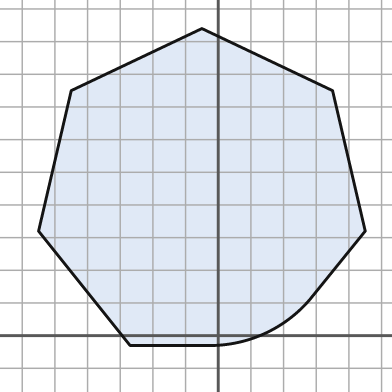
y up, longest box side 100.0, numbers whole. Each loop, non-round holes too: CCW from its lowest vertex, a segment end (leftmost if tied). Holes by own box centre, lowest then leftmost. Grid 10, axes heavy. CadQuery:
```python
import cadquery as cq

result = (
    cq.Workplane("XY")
    .moveTo(-27.0, -3.0)
    .lineTo(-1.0, -3.0)
    .threePointArc((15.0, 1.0), (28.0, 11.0))
    .lineTo(45.0, 32.0)
    .lineTo(35.0, 75.0)
    .lineTo(-5.0, 94.0)
    .lineTo(-45.0, 75.0)
    .lineTo(-55.0, 32.0)
    .close()
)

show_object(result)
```